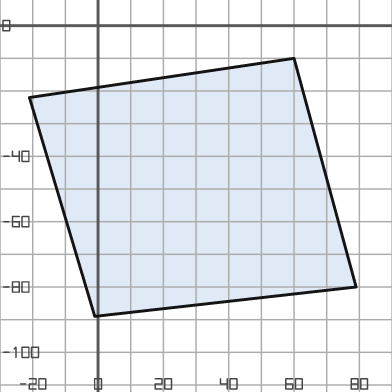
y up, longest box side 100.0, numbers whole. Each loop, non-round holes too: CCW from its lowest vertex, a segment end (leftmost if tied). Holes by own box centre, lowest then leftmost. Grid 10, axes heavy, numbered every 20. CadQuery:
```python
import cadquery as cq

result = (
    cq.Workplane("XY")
    .moveTo(-1.0, -89.0)
    .lineTo(79.0, -80.0)
    .lineTo(60.0, -10.0)
    .lineTo(-21.0, -22.0)
    .close()
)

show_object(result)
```